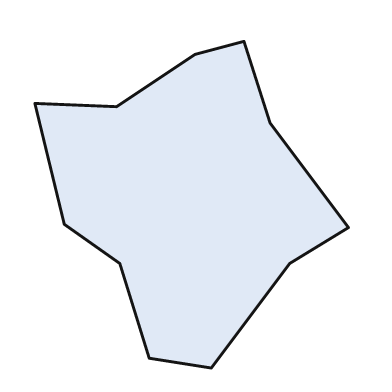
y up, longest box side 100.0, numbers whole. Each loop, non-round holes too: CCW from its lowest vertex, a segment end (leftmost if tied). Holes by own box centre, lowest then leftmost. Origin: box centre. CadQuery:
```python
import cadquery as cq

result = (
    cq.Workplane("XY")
    .moveTo(6.0, -50.0)
    .lineTo(30.0, -18.0)
    .lineTo(48.0, -7.0)
    .lineTo(24.0, 25.0)
    .lineTo(16.0, 50.0)
    .lineTo(1.0, 46.0)
    .lineTo(-23.0, 30.0)
    .lineTo(-48.0, 31.0)
    .lineTo(-39.0, -6.0)
    .lineTo(-22.0, -18.0)
    .lineTo(-13.0, -47.0)
    .close()
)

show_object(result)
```